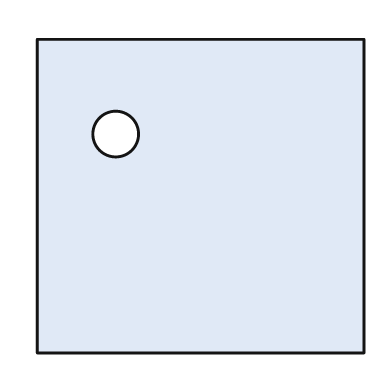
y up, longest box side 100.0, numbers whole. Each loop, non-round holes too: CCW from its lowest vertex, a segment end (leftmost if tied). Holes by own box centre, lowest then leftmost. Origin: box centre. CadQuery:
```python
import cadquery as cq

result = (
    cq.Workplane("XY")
    .moveTo(-50.0, -48.0)
    .lineTo(50.0, -48.0)
    .lineTo(50.0, 48.0)
    .lineTo(-50.0, 48.0)
    .close()
    .moveTo(-26.0, 19.0)
    .circle(7.0)
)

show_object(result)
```